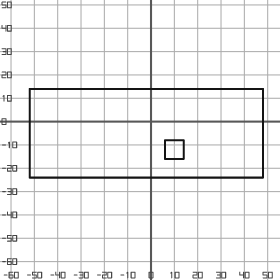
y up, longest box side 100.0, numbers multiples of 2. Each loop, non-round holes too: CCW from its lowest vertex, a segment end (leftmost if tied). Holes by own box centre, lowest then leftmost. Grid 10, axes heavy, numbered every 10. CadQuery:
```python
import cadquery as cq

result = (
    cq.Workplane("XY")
    .moveTo(-52.0, -24.0)
    .lineTo(48.0, -24.0)
    .lineTo(48.0, 14.0)
    .lineTo(-52.0, 14.0)
    .close()
    .moveTo(6.0, -16.0)
    .lineTo(14.0, -16.0)
    .lineTo(14.0, -8.0)
    .lineTo(6.0, -8.0)
    .close()
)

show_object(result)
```